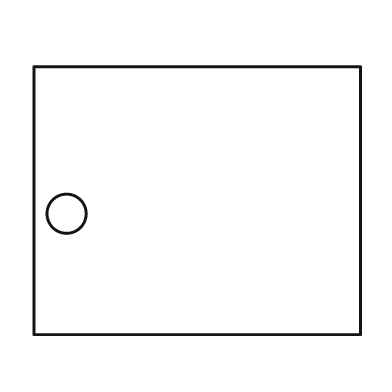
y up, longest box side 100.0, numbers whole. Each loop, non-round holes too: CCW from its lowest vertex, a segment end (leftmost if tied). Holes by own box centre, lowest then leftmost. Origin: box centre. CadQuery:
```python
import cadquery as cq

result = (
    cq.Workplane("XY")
    .moveTo(-50.0, -41.0)
    .lineTo(50.0, -41.0)
    .lineTo(50.0, 41.0)
    .lineTo(-50.0, 41.0)
    .close()
    .moveTo(-40.0, -4.0)
    .circle(6.0)
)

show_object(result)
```